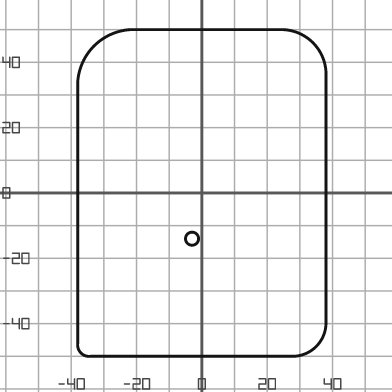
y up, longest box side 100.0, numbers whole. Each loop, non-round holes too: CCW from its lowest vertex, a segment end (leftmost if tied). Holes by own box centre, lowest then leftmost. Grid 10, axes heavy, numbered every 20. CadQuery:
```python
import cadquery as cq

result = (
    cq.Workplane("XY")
    .moveTo(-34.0, -50.0)
    .lineTo(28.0, -50.0)
    .threePointArc((35.0, -47.0), (38.0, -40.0))
    .lineTo(38.0, 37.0)
    .threePointArc((34.0, 46.0), (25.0, 50.0))
    .lineTo(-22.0, 50.0)
    .threePointArc((-33.0, 45.0), (-38.0, 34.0))
    .lineTo(-38.0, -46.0)
    .threePointArc((-37.0, -49.0), (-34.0, -50.0))
    .close()
    .moveTo(-3.0, -14.0)
    .circle(2.0)
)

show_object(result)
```